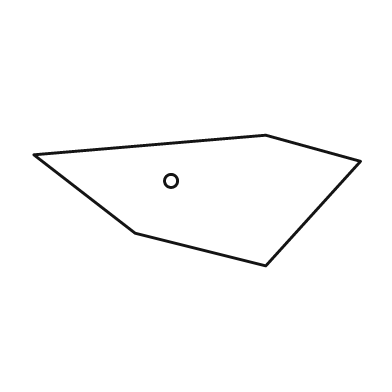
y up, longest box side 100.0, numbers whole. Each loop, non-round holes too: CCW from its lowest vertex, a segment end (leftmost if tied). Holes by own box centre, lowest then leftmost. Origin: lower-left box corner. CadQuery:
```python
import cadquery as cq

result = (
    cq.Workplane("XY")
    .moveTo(71.0, 0.0)
    .lineTo(100.0, 32.0)
    .lineTo(71.0, 40.0)
    .lineTo(0.0, 34.0)
    .lineTo(31.0, 10.0)
    .close()
    .moveTo(42.0, 26.0)
    .circle(2.0)
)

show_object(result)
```